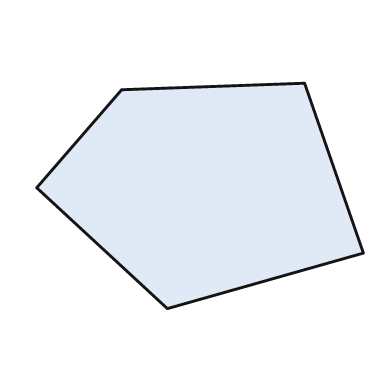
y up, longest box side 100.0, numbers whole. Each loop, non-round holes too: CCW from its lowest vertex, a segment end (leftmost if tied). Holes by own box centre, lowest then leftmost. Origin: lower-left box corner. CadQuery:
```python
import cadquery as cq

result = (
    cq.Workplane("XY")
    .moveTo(40.0, 0.0)
    .lineTo(100.0, 17.0)
    .lineTo(82.0, 69.0)
    .lineTo(26.0, 67.0)
    .lineTo(0.0, 37.0)
    .close()
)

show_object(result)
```